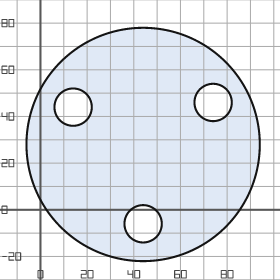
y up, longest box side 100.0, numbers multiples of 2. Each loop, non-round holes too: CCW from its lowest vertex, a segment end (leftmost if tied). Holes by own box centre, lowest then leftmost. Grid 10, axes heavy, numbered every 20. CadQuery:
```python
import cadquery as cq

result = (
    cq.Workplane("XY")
    .moveTo(44.0, 28.0)
    .circle(50.0)
    .moveTo(44.0, -6.0)
    .circle(8.0)
    .moveTo(14.0, 44.0)
    .circle(8.0)
    .moveTo(74.0, 46.0)
    .circle(8.0)
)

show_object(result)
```